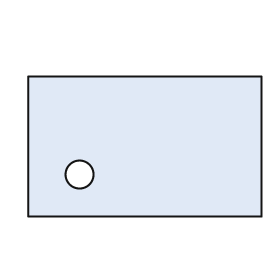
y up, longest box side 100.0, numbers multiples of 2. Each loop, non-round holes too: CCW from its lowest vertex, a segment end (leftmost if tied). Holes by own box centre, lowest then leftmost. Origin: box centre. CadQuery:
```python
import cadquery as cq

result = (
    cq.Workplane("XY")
    .moveTo(-50.0, -30.0)
    .lineTo(50.0, -30.0)
    .lineTo(50.0, 30.0)
    .lineTo(-50.0, 30.0)
    .close()
    .moveTo(-28.0, -12.0)
    .circle(6.0)
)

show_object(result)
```